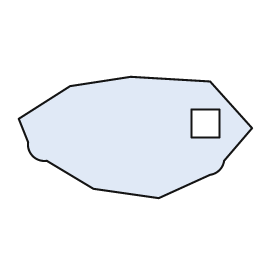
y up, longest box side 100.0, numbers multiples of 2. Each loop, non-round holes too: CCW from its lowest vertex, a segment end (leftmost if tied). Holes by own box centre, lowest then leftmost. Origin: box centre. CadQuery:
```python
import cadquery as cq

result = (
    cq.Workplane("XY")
    .moveTo(10.0, -26.0)
    .lineTo(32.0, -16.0)
    .threePointArc((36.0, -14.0), (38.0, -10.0))
    .lineTo(50.0, 4.0)
    .lineTo(32.0, 24.0)
    .lineTo(-2.0, 26.0)
    .lineTo(-28.0, 22.0)
    .lineTo(-50.0, 8.0)
    .lineTo(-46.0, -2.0)
    .threePointArc((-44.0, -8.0), (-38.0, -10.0))
    .lineTo(-18.0, -22.0)
    .close()
    .moveTo(24.0, 0.0)
    .lineTo(36.0, 0.0)
    .lineTo(36.0, 12.0)
    .lineTo(24.0, 12.0)
    .close()
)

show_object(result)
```